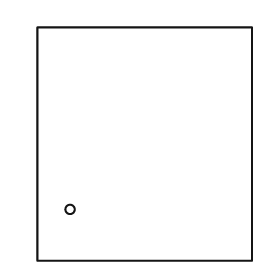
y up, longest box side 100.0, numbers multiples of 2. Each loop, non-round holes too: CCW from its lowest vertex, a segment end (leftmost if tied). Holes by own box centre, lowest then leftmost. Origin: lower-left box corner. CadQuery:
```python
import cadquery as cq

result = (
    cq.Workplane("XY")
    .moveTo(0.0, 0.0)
    .lineTo(92.0, 0.0)
    .lineTo(92.0, 100.0)
    .lineTo(0.0, 100.0)
    .close()
    .moveTo(14.0, 22.0)
    .circle(2.0)
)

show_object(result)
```